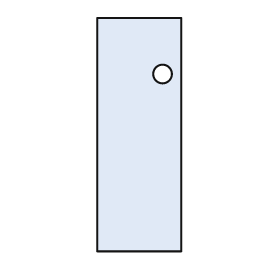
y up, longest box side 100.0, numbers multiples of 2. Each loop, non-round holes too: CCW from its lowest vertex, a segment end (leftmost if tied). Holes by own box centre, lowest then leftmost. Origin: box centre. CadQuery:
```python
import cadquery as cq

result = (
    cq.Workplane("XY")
    .moveTo(-18.0, -50.0)
    .lineTo(18.0, -50.0)
    .lineTo(18.0, 50.0)
    .lineTo(-18.0, 50.0)
    .close()
    .moveTo(10.0, 26.0)
    .circle(4.0)
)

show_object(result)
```